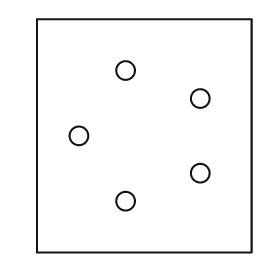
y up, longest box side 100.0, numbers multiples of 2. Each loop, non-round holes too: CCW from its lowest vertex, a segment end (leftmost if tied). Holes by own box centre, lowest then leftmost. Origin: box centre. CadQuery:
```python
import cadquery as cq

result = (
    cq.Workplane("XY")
    .moveTo(-46.0, -50.0)
    .lineTo(46.0, -50.0)
    .lineTo(46.0, 50.0)
    .lineTo(-46.0, 50.0)
    .close()
    .moveTo(-8.0, -28.0)
    .circle(4.0)
    .moveTo(24.0, -16.0)
    .circle(4.0)
    .moveTo(-28.0, 0.0)
    .circle(4.0)
    .moveTo(24.0, 16.0)
    .circle(4.0)
    .moveTo(-8.0, 28.0)
    .circle(4.0)
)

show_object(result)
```